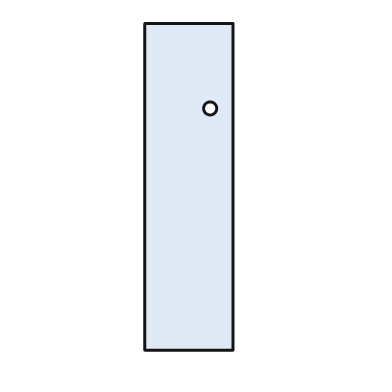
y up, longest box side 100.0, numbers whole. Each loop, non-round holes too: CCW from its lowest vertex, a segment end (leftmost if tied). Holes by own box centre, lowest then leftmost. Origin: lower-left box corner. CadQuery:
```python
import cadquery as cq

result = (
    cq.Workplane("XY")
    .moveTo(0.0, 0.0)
    .lineTo(27.0, 0.0)
    .lineTo(27.0, 100.0)
    .lineTo(0.0, 100.0)
    .close()
    .moveTo(20.0, 74.0)
    .circle(2.0)
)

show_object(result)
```